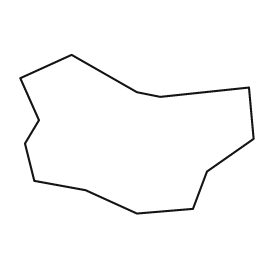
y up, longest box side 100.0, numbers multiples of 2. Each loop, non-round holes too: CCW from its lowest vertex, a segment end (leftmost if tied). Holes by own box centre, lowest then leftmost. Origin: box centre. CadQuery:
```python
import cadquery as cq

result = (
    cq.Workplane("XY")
    .moveTo(0.0, -34.0)
    .lineTo(24.0, -32.0)
    .lineTo(30.0, -16.0)
    .lineTo(50.0, -2.0)
    .lineTo(48.0, 20.0)
    .lineTo(10.0, 16.0)
    .lineTo(0.0, 18.0)
    .lineTo(-28.0, 34.0)
    .lineTo(-50.0, 24.0)
    .lineTo(-42.0, 6.0)
    .lineTo(-48.0, -4.0)
    .lineTo(-44.0, -20.0)
    .lineTo(-22.0, -24.0)
    .close()
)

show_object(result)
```